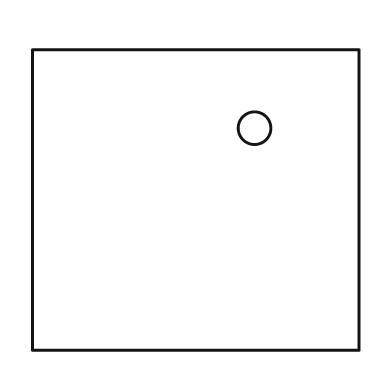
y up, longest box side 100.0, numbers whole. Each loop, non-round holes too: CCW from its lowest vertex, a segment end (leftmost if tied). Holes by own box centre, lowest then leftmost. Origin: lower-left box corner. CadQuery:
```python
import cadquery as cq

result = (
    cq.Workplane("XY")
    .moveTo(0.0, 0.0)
    .lineTo(100.0, 0.0)
    .lineTo(100.0, 92.0)
    .lineTo(0.0, 92.0)
    .close()
    .moveTo(68.0, 68.0)
    .circle(5.0)
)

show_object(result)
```